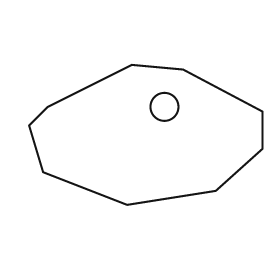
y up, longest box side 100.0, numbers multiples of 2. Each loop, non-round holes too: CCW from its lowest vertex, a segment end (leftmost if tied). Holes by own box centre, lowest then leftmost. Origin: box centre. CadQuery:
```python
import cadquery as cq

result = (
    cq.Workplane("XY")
    .moveTo(-8.0, -30.0)
    .lineTo(30.0, -24.0)
    .lineTo(50.0, -6.0)
    .lineTo(50.0, 10.0)
    .lineTo(16.0, 28.0)
    .lineTo(-6.0, 30.0)
    .lineTo(-42.0, 12.0)
    .lineTo(-50.0, 4.0)
    .lineTo(-44.0, -16.0)
    .close()
    .moveTo(8.0, 12.0)
    .circle(6.0)
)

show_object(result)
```